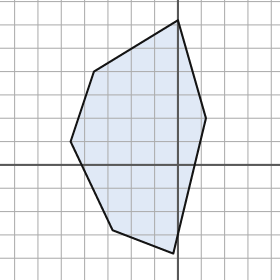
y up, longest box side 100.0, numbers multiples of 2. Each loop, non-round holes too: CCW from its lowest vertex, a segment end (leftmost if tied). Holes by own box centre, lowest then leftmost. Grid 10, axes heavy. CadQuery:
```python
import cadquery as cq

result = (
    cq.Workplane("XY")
    .moveTo(-2.0, -38.0)
    .lineTo(12.0, 20.0)
    .lineTo(0.0, 62.0)
    .lineTo(-36.0, 40.0)
    .lineTo(-46.0, 10.0)
    .lineTo(-28.0, -28.0)
    .close()
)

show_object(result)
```